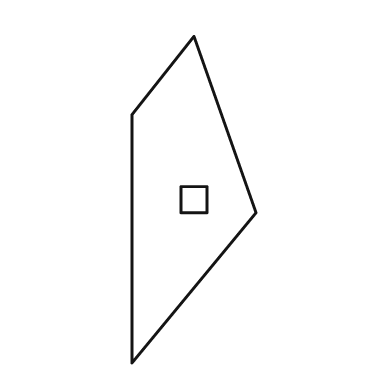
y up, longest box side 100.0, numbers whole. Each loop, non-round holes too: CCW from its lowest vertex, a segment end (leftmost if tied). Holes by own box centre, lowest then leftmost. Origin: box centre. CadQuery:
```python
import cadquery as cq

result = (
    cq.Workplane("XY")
    .moveTo(-19.0, -50.0)
    .lineTo(19.0, -4.0)
    .lineTo(0.0, 50.0)
    .lineTo(-19.0, 26.0)
    .close()
    .moveTo(-4.0, -4.0)
    .lineTo(4.0, -4.0)
    .lineTo(4.0, 4.0)
    .lineTo(-4.0, 4.0)
    .close()
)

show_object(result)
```